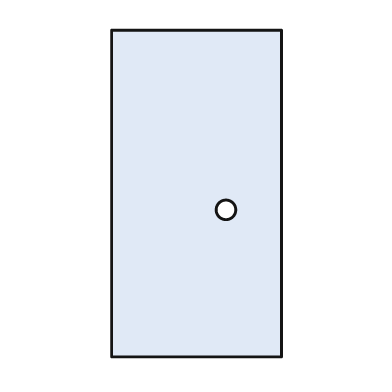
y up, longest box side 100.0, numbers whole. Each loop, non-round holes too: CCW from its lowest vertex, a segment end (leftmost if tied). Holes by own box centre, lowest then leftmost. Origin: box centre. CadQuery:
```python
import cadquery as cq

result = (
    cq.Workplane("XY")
    .moveTo(-26.0, -50.0)
    .lineTo(26.0, -50.0)
    .lineTo(26.0, 50.0)
    .lineTo(-26.0, 50.0)
    .close()
    .moveTo(9.0, -5.0)
    .circle(3.0)
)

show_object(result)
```